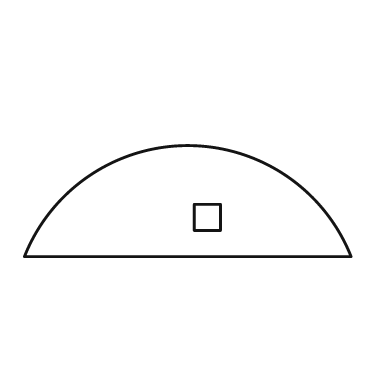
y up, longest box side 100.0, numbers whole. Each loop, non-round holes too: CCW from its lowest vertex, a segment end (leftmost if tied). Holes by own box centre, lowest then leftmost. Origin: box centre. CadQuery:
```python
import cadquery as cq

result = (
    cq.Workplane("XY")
    .moveTo(-50.0, -17.0)
    .lineTo(50.0, -17.0)
    .threePointArc((0.0, 17.0), (-50.0, -17.0))
    .close()
    .moveTo(2.0, -9.0)
    .lineTo(10.0, -9.0)
    .lineTo(10.0, -1.0)
    .lineTo(2.0, -1.0)
    .close()
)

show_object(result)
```